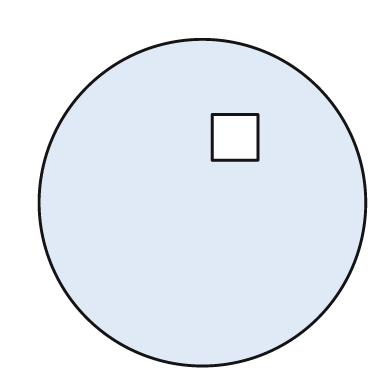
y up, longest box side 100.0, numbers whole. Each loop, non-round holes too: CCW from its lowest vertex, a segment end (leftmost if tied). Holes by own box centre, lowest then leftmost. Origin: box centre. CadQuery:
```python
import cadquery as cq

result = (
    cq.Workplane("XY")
    .moveTo(0.0, 0.0)
    .circle(50.0)
    .moveTo(3.0, 13.0)
    .lineTo(17.0, 13.0)
    .lineTo(17.0, 27.0)
    .lineTo(3.0, 27.0)
    .close()
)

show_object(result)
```